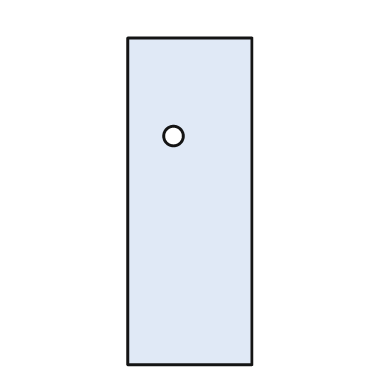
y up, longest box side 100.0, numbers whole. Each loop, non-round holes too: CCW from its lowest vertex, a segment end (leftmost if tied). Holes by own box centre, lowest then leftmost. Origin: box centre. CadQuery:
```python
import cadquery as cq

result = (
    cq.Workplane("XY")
    .moveTo(-19.0, -50.0)
    .lineTo(19.0, -50.0)
    .lineTo(19.0, 50.0)
    .lineTo(-19.0, 50.0)
    .close()
    .moveTo(-5.0, 20.0)
    .circle(3.0)
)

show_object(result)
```